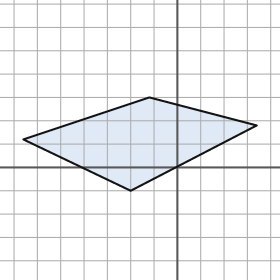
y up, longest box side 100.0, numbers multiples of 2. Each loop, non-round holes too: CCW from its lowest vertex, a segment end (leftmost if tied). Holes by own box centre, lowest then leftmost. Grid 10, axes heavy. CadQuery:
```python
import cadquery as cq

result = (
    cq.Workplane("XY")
    .moveTo(-20.0, -10.0)
    .lineTo(34.0, 18.0)
    .lineTo(-12.0, 30.0)
    .lineTo(-66.0, 12.0)
    .close()
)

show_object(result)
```